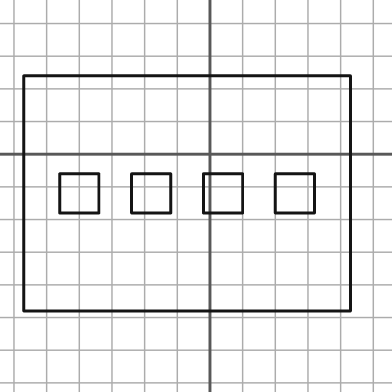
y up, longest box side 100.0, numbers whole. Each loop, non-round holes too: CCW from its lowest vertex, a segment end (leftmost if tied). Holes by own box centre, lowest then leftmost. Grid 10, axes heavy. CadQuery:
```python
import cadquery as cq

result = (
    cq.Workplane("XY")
    .moveTo(-57.0, -48.0)
    .lineTo(43.0, -48.0)
    .lineTo(43.0, 24.0)
    .lineTo(-57.0, 24.0)
    .close()
    .moveTo(-46.0, -18.0)
    .lineTo(-34.0, -18.0)
    .lineTo(-34.0, -6.0)
    .lineTo(-46.0, -6.0)
    .close()
    .moveTo(-24.0, -18.0)
    .lineTo(-12.0, -18.0)
    .lineTo(-12.0, -6.0)
    .lineTo(-24.0, -6.0)
    .close()
    .moveTo(-2.0, -18.0)
    .lineTo(10.0, -18.0)
    .lineTo(10.0, -6.0)
    .lineTo(-2.0, -6.0)
    .close()
    .moveTo(20.0, -18.0)
    .lineTo(32.0, -18.0)
    .lineTo(32.0, -6.0)
    .lineTo(20.0, -6.0)
    .close()
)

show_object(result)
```